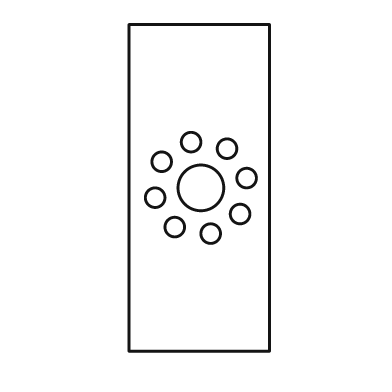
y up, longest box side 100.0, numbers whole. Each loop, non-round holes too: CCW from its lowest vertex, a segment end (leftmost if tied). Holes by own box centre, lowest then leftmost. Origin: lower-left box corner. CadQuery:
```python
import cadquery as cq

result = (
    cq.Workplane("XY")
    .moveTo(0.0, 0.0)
    .lineTo(43.0, 0.0)
    .lineTo(43.0, 100.0)
    .lineTo(0.0, 100.0)
    .close()
    .moveTo(25.0, 36.0)
    .circle(3.0)
    .moveTo(14.0, 38.0)
    .circle(3.0)
    .moveTo(34.0, 42.0)
    .circle(3.0)
    .moveTo(8.0, 47.0)
    .circle(3.0)
    .moveTo(22.0, 50.0)
    .circle(7.0)
    .moveTo(36.0, 53.0)
    .circle(3.0)
    .moveTo(10.0, 58.0)
    .circle(3.0)
    .moveTo(30.0, 62.0)
    .circle(3.0)
    .moveTo(19.0, 64.0)
    .circle(3.0)
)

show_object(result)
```